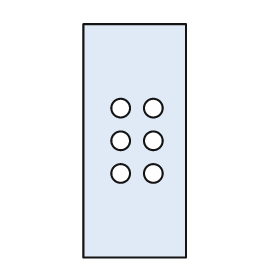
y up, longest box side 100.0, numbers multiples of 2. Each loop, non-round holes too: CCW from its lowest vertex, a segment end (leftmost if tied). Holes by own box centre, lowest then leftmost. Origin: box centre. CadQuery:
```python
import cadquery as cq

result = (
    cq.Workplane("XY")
    .moveTo(-22.0, -50.0)
    .lineTo(22.0, -50.0)
    .lineTo(22.0, 50.0)
    .lineTo(-22.0, 50.0)
    .close()
    .moveTo(-6.0, -14.0)
    .circle(4.0)
    .moveTo(8.0, -14.0)
    .circle(4.0)
    .moveTo(-6.0, 0.0)
    .circle(4.0)
    .moveTo(8.0, 0.0)
    .circle(4.0)
    .moveTo(-6.0, 14.0)
    .circle(4.0)
    .moveTo(8.0, 14.0)
    .circle(4.0)
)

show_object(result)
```